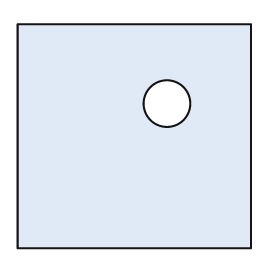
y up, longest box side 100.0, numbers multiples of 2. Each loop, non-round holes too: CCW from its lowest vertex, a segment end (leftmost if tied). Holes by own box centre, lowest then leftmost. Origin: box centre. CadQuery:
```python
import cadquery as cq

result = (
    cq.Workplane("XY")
    .moveTo(-50.0, -48.0)
    .lineTo(50.0, -48.0)
    .lineTo(50.0, 48.0)
    .lineTo(-50.0, 48.0)
    .close()
    .moveTo(14.0, 14.0)
    .circle(10.0)
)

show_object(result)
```